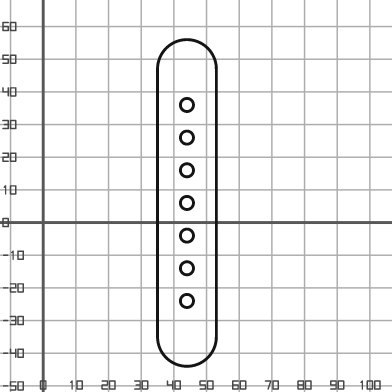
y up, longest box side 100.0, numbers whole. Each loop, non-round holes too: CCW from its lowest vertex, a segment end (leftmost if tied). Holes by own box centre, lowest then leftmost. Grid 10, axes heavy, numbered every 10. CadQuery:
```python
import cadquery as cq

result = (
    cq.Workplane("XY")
    .moveTo(35.0, -35.0)
    .threePointArc((44.0, -44.0), (53.0, -35.0))
    .lineTo(53.0, 47.0)
    .threePointArc((44.0, 56.0), (35.0, 47.0))
    .close()
    .moveTo(44.0, -24.0)
    .circle(2.0)
    .moveTo(44.0, -14.0)
    .circle(2.0)
    .moveTo(44.0, -4.0)
    .circle(2.0)
    .moveTo(44.0, 6.0)
    .circle(2.0)
    .moveTo(44.0, 16.0)
    .circle(2.0)
    .moveTo(44.0, 26.0)
    .circle(2.0)
    .moveTo(44.0, 36.0)
    .circle(2.0)
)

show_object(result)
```